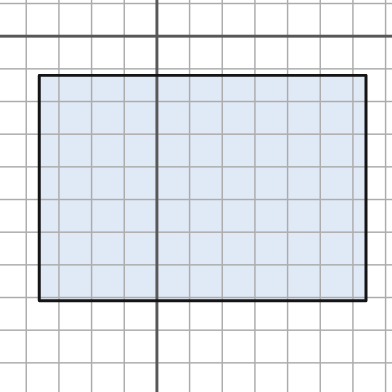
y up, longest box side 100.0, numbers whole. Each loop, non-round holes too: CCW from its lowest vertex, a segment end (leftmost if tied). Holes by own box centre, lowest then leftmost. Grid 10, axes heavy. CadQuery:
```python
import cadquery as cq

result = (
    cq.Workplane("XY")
    .moveTo(-36.0, -81.0)
    .lineTo(64.0, -81.0)
    .lineTo(64.0, -12.0)
    .lineTo(-36.0, -12.0)
    .close()
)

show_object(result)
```